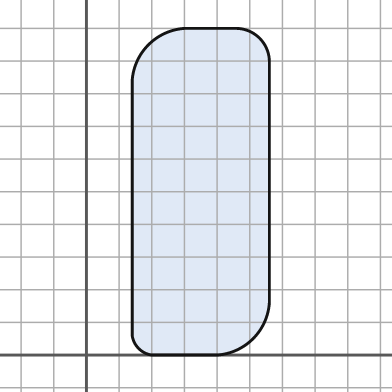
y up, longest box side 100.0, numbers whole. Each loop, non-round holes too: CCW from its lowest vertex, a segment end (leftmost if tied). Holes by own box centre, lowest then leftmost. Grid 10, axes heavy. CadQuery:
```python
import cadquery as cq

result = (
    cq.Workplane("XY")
    .moveTo(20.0, 0.0)
    .lineTo(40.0, 0.0)
    .threePointArc((51.0, 5.0), (56.0, 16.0))
    .lineTo(56.0, 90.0)
    .threePointArc((53.0, 97.0), (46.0, 100.0))
    .lineTo(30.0, 100.0)
    .threePointArc((19.0, 95.0), (14.0, 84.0))
    .lineTo(14.0, 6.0)
    .threePointArc((16.0, 2.0), (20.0, 0.0))
    .close()
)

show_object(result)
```